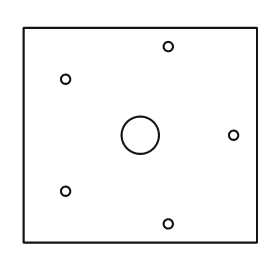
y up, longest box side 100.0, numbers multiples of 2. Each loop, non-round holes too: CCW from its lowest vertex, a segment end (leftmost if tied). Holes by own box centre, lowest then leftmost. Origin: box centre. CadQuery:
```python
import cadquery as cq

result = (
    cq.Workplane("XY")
    .moveTo(-50.0, -46.0)
    .lineTo(50.0, -46.0)
    .lineTo(50.0, 46.0)
    .lineTo(-50.0, 46.0)
    .close()
    .moveTo(12.0, -38.0)
    .circle(2.0)
    .moveTo(-32.0, -24.0)
    .circle(2.0)
    .moveTo(0.0, 0.0)
    .circle(8.0)
    .moveTo(40.0, 0.0)
    .circle(2.0)
    .moveTo(-32.0, 24.0)
    .circle(2.0)
    .moveTo(12.0, 38.0)
    .circle(2.0)
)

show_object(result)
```